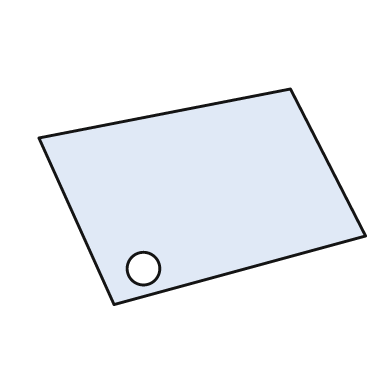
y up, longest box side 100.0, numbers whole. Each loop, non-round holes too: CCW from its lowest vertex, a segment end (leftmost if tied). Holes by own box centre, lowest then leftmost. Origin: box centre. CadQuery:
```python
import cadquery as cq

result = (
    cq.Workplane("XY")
    .moveTo(-27.0, -33.0)
    .lineTo(50.0, -12.0)
    .lineTo(27.0, 33.0)
    .lineTo(-50.0, 18.0)
    .close()
    .moveTo(-18.0, -22.0)
    .circle(5.0)
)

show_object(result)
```